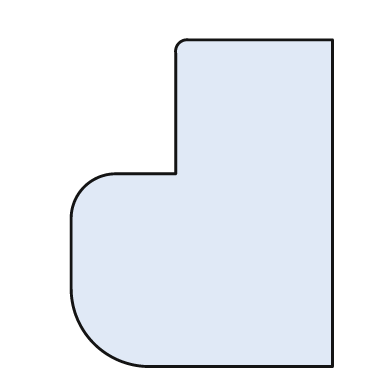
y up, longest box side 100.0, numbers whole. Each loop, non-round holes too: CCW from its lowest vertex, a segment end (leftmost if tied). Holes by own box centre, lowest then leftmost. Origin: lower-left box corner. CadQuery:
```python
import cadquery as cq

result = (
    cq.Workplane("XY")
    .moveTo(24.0, 0.0)
    .lineTo(80.0, 0.0)
    .lineTo(80.0, 100.0)
    .lineTo(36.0, 100.0)
    .threePointArc((33.0, 99.0), (32.0, 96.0))
    .lineTo(32.0, 59.0)
    .lineTo(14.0, 59.0)
    .threePointArc((4.0, 55.0), (0.0, 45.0))
    .lineTo(0.0, 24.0)
    .threePointArc((7.0, 7.0), (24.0, 0.0))
    .close()
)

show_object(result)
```